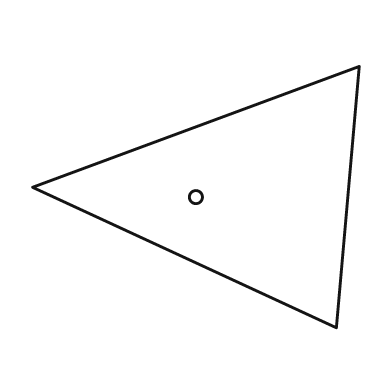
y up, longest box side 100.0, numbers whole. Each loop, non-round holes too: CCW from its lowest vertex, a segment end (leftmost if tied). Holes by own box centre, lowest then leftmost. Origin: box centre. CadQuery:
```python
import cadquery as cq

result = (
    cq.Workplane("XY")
    .moveTo(43.0, -40.0)
    .lineTo(50.0, 40.0)
    .lineTo(-50.0, 3.0)
    .close()
    .moveTo(0.0, 0.0)
    .circle(2.0)
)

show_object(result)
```